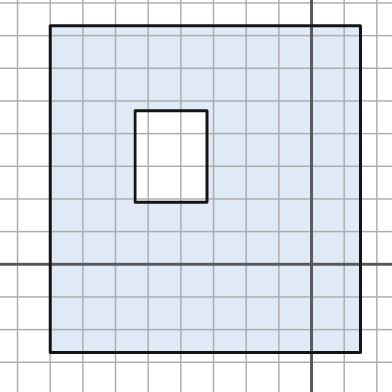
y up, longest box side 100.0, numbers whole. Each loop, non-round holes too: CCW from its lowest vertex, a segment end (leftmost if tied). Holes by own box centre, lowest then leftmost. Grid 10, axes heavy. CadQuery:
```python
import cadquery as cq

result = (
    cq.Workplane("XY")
    .moveTo(-80.0, -27.0)
    .lineTo(15.0, -27.0)
    .lineTo(15.0, 73.0)
    .lineTo(-80.0, 73.0)
    .close()
    .moveTo(-54.0, 19.0)
    .lineTo(-32.0, 19.0)
    .lineTo(-32.0, 47.0)
    .lineTo(-54.0, 47.0)
    .close()
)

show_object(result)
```